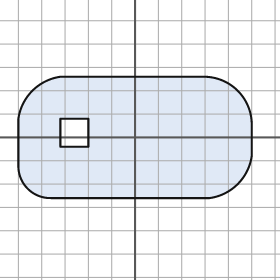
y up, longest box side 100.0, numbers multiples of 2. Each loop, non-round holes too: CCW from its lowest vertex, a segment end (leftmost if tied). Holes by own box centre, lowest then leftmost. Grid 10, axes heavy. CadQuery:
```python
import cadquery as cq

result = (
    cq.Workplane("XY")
    .moveTo(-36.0, -26.0)
    .lineTo(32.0, -26.0)
    .threePointArc((44.0, -20.0), (50.0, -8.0))
    .lineTo(50.0, 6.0)
    .threePointArc((44.0, 20.0), (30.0, 26.0))
    .lineTo(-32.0, 26.0)
    .threePointArc((-44.0, 20.0), (-50.0, 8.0))
    .lineTo(-50.0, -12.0)
    .threePointArc((-46.0, -22.0), (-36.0, -26.0))
    .close()
    .moveTo(-32.0, -4.0)
    .lineTo(-20.0, -4.0)
    .lineTo(-20.0, 8.0)
    .lineTo(-32.0, 8.0)
    .close()
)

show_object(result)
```